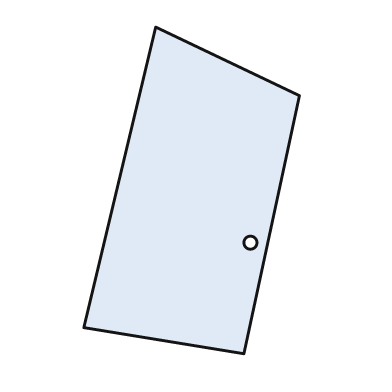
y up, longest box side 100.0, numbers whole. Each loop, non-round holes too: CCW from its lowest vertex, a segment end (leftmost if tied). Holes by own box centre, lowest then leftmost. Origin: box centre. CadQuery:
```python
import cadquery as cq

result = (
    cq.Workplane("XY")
    .moveTo(16.0, -50.0)
    .lineTo(33.0, 29.0)
    .lineTo(-11.0, 50.0)
    .lineTo(-33.0, -42.0)
    .close()
    .moveTo(18.0, -16.0)
    .circle(2.0)
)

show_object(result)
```